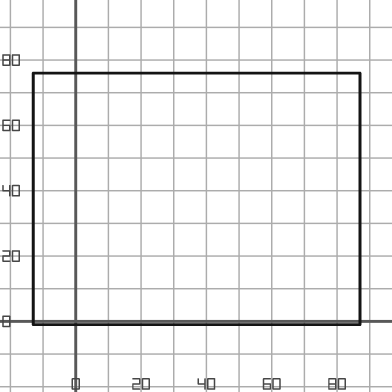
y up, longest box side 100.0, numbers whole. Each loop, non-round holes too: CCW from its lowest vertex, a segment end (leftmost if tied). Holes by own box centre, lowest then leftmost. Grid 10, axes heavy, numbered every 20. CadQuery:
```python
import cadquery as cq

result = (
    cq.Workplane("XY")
    .moveTo(-13.0, -1.0)
    .lineTo(87.0, -1.0)
    .lineTo(87.0, 76.0)
    .lineTo(-13.0, 76.0)
    .close()
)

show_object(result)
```